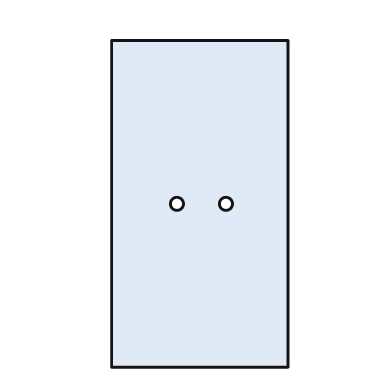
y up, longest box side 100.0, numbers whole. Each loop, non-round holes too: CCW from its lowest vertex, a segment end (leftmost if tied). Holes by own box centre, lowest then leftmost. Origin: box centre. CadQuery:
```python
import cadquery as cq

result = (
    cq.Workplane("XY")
    .moveTo(-27.0, -50.0)
    .lineTo(27.0, -50.0)
    .lineTo(27.0, 50.0)
    .lineTo(-27.0, 50.0)
    .close()
    .moveTo(-7.0, 0.0)
    .circle(2.0)
    .moveTo(8.0, 0.0)
    .circle(2.0)
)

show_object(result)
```